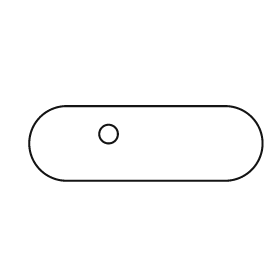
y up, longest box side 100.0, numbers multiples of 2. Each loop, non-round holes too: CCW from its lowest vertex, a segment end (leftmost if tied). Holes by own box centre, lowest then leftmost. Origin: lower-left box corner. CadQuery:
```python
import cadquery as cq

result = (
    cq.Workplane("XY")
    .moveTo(16.0, 0.0)
    .lineTo(84.0, 0.0)
    .threePointArc((100.0, 16.0), (84.0, 32.0))
    .lineTo(16.0, 32.0)
    .threePointArc((0.0, 16.0), (16.0, 0.0))
    .close()
    .moveTo(34.0, 20.0)
    .circle(4.0)
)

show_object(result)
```